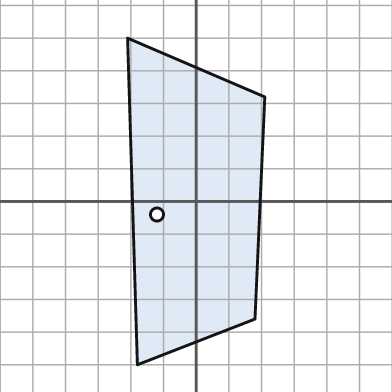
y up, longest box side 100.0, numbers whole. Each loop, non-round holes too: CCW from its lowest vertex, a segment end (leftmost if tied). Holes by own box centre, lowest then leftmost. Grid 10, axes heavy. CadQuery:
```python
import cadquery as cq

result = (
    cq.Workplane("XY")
    .moveTo(-18.0, -50.0)
    .lineTo(18.0, -36.0)
    .lineTo(21.0, 32.0)
    .lineTo(-21.0, 50.0)
    .close()
    .moveTo(-12.0, -4.0)
    .circle(2.0)
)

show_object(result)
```